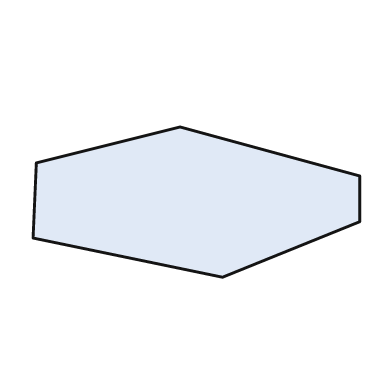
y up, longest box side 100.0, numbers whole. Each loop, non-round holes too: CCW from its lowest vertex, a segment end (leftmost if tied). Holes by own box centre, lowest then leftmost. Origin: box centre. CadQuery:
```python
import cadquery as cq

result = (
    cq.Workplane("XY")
    .moveTo(8.0, -23.0)
    .lineTo(50.0, -6.0)
    .lineTo(50.0, 8.0)
    .lineTo(-5.0, 23.0)
    .lineTo(-49.0, 12.0)
    .lineTo(-50.0, -11.0)
    .close()
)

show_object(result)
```